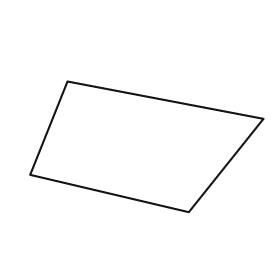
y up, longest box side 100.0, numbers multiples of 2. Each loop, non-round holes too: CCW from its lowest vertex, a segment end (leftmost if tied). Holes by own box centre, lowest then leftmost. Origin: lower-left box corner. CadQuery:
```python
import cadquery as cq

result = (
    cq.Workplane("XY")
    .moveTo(68.0, 0.0)
    .lineTo(100.0, 40.0)
    .lineTo(16.0, 56.0)
    .lineTo(0.0, 16.0)
    .close()
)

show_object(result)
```